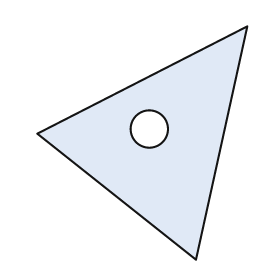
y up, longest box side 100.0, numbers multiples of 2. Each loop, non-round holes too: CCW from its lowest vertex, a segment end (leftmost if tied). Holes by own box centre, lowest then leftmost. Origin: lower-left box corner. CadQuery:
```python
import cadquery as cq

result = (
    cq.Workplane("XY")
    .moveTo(68.0, 0.0)
    .lineTo(90.0, 100.0)
    .lineTo(0.0, 54.0)
    .close()
    .moveTo(48.0, 56.0)
    .circle(8.0)
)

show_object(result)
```